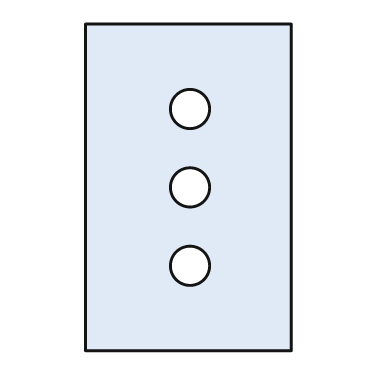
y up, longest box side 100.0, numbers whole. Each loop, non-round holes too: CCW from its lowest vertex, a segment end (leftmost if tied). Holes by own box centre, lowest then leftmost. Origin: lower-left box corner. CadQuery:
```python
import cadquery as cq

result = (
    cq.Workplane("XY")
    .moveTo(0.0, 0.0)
    .lineTo(63.0, 0.0)
    .lineTo(63.0, 100.0)
    .lineTo(0.0, 100.0)
    .close()
    .moveTo(32.0, 26.0)
    .circle(6.0)
    .moveTo(32.0, 50.0)
    .circle(6.0)
    .moveTo(32.0, 74.0)
    .circle(6.0)
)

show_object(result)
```